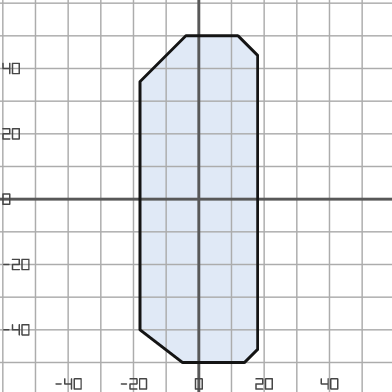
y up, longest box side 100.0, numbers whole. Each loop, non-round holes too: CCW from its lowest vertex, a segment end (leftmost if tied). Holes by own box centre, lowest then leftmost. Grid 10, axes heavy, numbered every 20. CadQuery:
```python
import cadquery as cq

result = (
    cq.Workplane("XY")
    .moveTo(-5.0, -50.0)
    .lineTo(14.0, -50.0)
    .lineTo(18.0, -46.0)
    .lineTo(18.0, 44.0)
    .lineTo(12.0, 50.0)
    .lineTo(-4.0, 50.0)
    .lineTo(-18.0, 36.0)
    .lineTo(-18.0, -40.0)
    .close()
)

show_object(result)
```